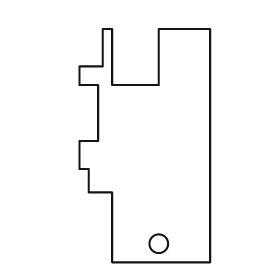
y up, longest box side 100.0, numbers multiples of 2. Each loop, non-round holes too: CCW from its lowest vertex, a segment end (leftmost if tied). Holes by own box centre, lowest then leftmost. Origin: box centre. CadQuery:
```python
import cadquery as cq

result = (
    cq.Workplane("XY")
    .moveTo(-14.0, -50.0)
    .lineTo(28.0, -50.0)
    .lineTo(28.0, 50.0)
    .lineTo(6.0, 50.0)
    .lineTo(6.0, 26.0)
    .lineTo(-14.0, 26.0)
    .lineTo(-14.0, 50.0)
    .lineTo(-18.0, 50.0)
    .lineTo(-18.0, 34.0)
    .lineTo(-28.0, 34.0)
    .lineTo(-28.0, 26.0)
    .lineTo(-20.0, 26.0)
    .lineTo(-20.0, 2.0)
    .lineTo(-28.0, 2.0)
    .lineTo(-28.0, -10.0)
    .lineTo(-24.0, -10.0)
    .lineTo(-24.0, -20.0)
    .lineTo(-14.0, -20.0)
    .close()
    .moveTo(6.0, -42.0)
    .circle(4.0)
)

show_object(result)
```